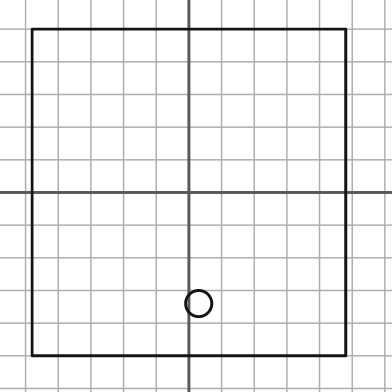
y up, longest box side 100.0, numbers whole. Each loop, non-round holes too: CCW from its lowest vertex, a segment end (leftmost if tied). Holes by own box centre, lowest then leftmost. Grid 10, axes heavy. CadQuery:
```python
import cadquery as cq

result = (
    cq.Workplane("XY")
    .moveTo(-48.0, -50.0)
    .lineTo(48.0, -50.0)
    .lineTo(48.0, 50.0)
    .lineTo(-48.0, 50.0)
    .close()
    .moveTo(3.0, -34.0)
    .circle(4.0)
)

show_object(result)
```